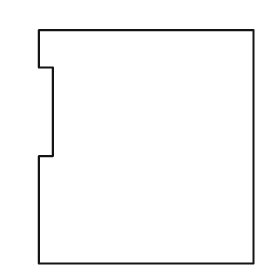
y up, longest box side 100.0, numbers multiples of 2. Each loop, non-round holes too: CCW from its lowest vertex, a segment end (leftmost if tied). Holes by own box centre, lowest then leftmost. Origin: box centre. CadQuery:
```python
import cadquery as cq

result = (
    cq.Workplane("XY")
    .moveTo(-46.0, -50.0)
    .lineTo(46.0, -50.0)
    .lineTo(46.0, 50.0)
    .lineTo(-46.0, 50.0)
    .lineTo(-46.0, 34.0)
    .lineTo(-40.0, 34.0)
    .lineTo(-40.0, -4.0)
    .lineTo(-46.0, -4.0)
    .close()
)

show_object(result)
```